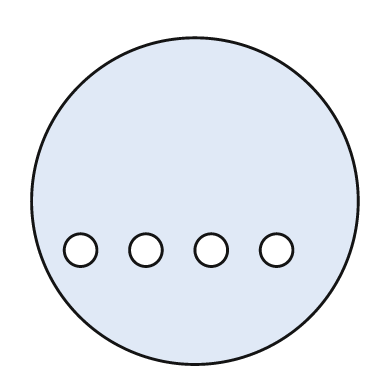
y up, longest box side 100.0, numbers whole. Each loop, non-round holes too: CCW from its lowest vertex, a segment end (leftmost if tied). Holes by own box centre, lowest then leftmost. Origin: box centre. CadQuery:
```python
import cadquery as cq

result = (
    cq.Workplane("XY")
    .moveTo(0.0, 0.0)
    .circle(50.0)
    .moveTo(-35.0, -15.0)
    .circle(5.0)
    .moveTo(-15.0, -15.0)
    .circle(5.0)
    .moveTo(5.0, -15.0)
    .circle(5.0)
    .moveTo(25.0, -15.0)
    .circle(5.0)
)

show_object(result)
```